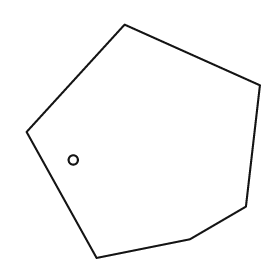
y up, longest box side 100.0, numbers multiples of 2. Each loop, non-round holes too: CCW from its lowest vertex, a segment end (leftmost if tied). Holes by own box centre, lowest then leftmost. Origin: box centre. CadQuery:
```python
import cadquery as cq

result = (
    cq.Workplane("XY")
    .moveTo(-20.0, -50.0)
    .lineTo(20.0, -42.0)
    .lineTo(44.0, -28.0)
    .lineTo(50.0, 24.0)
    .lineTo(-8.0, 50.0)
    .lineTo(-50.0, 4.0)
    .close()
    .moveTo(-30.0, -8.0)
    .circle(2.0)
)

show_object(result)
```